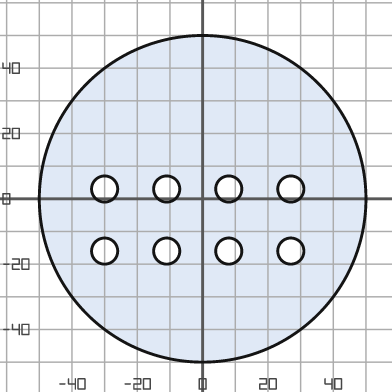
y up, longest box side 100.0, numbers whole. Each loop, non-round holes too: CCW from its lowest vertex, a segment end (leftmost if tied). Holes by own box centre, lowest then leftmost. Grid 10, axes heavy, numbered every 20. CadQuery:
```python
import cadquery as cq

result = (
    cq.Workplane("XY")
    .moveTo(0.0, 0.0)
    .circle(50.0)
    .moveTo(-30.0, -16.0)
    .circle(4.0)
    .moveTo(-11.0, -16.0)
    .circle(4.0)
    .moveTo(8.0, -16.0)
    .circle(4.0)
    .moveTo(27.0, -16.0)
    .circle(4.0)
    .moveTo(-30.0, 3.0)
    .circle(4.0)
    .moveTo(-11.0, 3.0)
    .circle(4.0)
    .moveTo(8.0, 3.0)
    .circle(4.0)
    .moveTo(27.0, 3.0)
    .circle(4.0)
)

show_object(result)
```